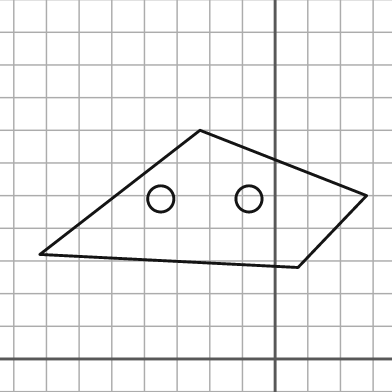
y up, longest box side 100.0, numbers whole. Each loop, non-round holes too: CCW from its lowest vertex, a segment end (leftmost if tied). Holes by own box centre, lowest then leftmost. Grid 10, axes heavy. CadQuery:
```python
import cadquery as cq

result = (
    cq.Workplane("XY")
    .moveTo(7.0, 28.0)
    .lineTo(28.0, 50.0)
    .lineTo(-23.0, 70.0)
    .lineTo(-72.0, 32.0)
    .close()
    .moveTo(-35.0, 49.0)
    .circle(4.0)
    .moveTo(-8.0, 49.0)
    .circle(4.0)
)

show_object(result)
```